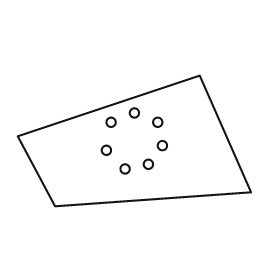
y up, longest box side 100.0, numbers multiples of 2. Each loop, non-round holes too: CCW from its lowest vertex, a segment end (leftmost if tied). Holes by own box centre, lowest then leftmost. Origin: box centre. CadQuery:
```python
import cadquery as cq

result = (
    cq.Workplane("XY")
    .moveTo(-34.0, -28.0)
    .lineTo(50.0, -22.0)
    .lineTo(28.0, 28.0)
    .lineTo(-50.0, 2.0)
    .close()
    .moveTo(-4.0, -12.0)
    .circle(2.0)
    .moveTo(6.0, -10.0)
    .circle(2.0)
    .moveTo(-12.0, -4.0)
    .circle(2.0)
    .moveTo(12.0, -2.0)
    .circle(2.0)
    .moveTo(-10.0, 8.0)
    .circle(2.0)
    .moveTo(10.0, 8.0)
    .circle(2.0)
    .moveTo(0.0, 12.0)
    .circle(2.0)
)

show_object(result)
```